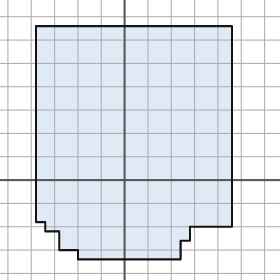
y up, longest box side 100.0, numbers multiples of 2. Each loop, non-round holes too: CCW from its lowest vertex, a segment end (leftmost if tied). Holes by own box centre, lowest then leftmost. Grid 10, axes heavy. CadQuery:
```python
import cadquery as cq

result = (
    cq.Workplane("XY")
    .moveTo(-20.0, -34.0)
    .lineTo(24.0, -34.0)
    .lineTo(24.0, -26.0)
    .lineTo(28.0, -26.0)
    .lineTo(28.0, -20.0)
    .lineTo(46.0, -20.0)
    .lineTo(46.0, 66.0)
    .lineTo(-38.0, 66.0)
    .lineTo(-38.0, -18.0)
    .lineTo(-34.0, -18.0)
    .lineTo(-34.0, -22.0)
    .lineTo(-28.0, -22.0)
    .lineTo(-28.0, -30.0)
    .lineTo(-20.0, -30.0)
    .close()
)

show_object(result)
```